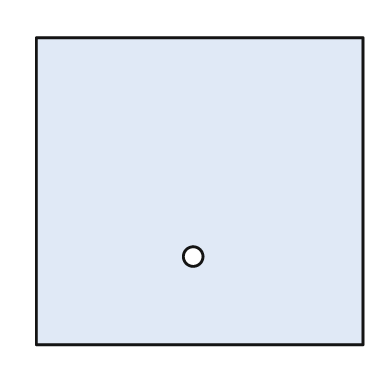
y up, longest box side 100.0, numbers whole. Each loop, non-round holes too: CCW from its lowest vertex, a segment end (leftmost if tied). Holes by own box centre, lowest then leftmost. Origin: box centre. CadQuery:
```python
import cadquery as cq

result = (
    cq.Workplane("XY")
    .moveTo(-50.0, -47.0)
    .lineTo(50.0, -47.0)
    .lineTo(50.0, 47.0)
    .lineTo(-50.0, 47.0)
    .close()
    .moveTo(-2.0, -20.0)
    .circle(3.0)
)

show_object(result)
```